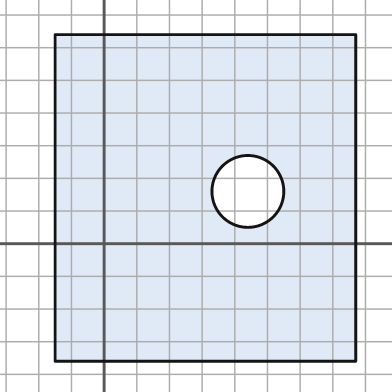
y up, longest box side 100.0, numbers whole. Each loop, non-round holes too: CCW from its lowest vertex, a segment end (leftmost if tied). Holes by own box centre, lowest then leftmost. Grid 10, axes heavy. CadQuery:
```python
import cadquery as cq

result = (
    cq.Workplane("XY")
    .moveTo(-15.0, -36.0)
    .lineTo(77.0, -36.0)
    .lineTo(77.0, 64.0)
    .lineTo(-15.0, 64.0)
    .close()
    .moveTo(44.0, 16.0)
    .circle(11.0)
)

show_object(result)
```